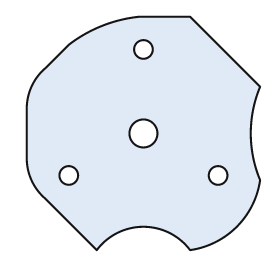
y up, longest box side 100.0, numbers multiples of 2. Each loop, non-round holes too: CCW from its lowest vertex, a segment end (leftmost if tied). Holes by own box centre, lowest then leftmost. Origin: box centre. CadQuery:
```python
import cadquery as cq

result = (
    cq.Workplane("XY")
    .moveTo(-20.0, -50.0)
    .threePointArc((0.0, -40.0), (20.0, -50.0))
    .threePointArc((40.0, -40.0), (50.0, -20.0))
    .threePointArc((46.0, 0.0), (50.0, 20.0))
    .lineTo(20.0, 50.0)
    .lineTo(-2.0, 50.0)
    .threePointArc((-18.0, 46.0), (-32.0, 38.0))
    .lineTo(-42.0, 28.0)
    .threePointArc((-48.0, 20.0), (-50.0, 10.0))
    .lineTo(-50.0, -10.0)
    .threePointArc((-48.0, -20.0), (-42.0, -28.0))
    .close()
    .moveTo(-32.0, -18.0)
    .circle(4.0)
    .moveTo(32.0, -18.0)
    .circle(4.0)
    .moveTo(0.0, 0.0)
    .circle(6.0)
    .moveTo(0.0, 36.0)
    .circle(4.0)
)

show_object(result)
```